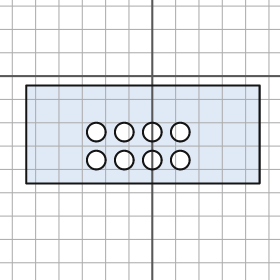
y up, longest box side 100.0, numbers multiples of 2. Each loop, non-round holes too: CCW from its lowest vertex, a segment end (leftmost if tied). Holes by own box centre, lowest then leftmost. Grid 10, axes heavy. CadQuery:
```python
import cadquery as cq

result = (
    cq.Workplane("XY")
    .moveTo(-54.0, -46.0)
    .lineTo(46.0, -46.0)
    .lineTo(46.0, -4.0)
    .lineTo(-54.0, -4.0)
    .close()
    .moveTo(-24.0, -36.0)
    .circle(4.0)
    .moveTo(-12.0, -36.0)
    .circle(4.0)
    .moveTo(0.0, -36.0)
    .circle(4.0)
    .moveTo(12.0, -36.0)
    .circle(4.0)
    .moveTo(-24.0, -24.0)
    .circle(4.0)
    .moveTo(-12.0, -24.0)
    .circle(4.0)
    .moveTo(0.0, -24.0)
    .circle(4.0)
    .moveTo(12.0, -24.0)
    .circle(4.0)
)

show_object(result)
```